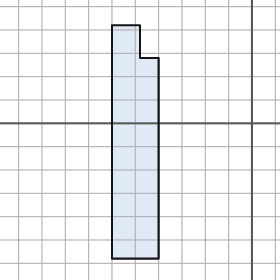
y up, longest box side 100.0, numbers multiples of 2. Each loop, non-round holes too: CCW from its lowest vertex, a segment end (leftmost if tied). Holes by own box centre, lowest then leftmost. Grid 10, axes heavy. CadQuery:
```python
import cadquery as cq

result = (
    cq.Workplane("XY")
    .moveTo(-60.0, -58.0)
    .lineTo(-40.0, -58.0)
    .lineTo(-40.0, 28.0)
    .lineTo(-48.0, 28.0)
    .lineTo(-48.0, 42.0)
    .lineTo(-60.0, 42.0)
    .close()
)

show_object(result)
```